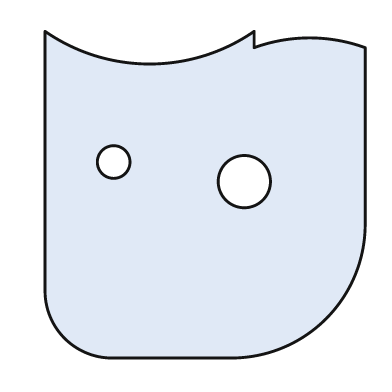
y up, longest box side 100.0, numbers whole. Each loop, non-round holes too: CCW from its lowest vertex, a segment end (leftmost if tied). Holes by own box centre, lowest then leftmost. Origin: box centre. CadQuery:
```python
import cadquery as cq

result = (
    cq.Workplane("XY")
    .moveTo(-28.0, -50.0)
    .lineTo(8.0, -50.0)
    .threePointArc((37.0, -38.0), (49.0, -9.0))
    .lineTo(49.0, 45.0)
    .threePointArc((32.0, 48.0), (15.0, 45.0))
    .lineTo(15.0, 50.0)
    .threePointArc((-17.0, 40.0), (-49.0, 50.0))
    .lineTo(-49.0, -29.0)
    .threePointArc((-43.0, -44.0), (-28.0, -50.0))
    .close()
    .moveTo(12.0, 4.0)
    .circle(8.0)
    .moveTo(-28.0, 10.0)
    .circle(5.0)
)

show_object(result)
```